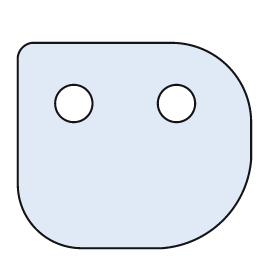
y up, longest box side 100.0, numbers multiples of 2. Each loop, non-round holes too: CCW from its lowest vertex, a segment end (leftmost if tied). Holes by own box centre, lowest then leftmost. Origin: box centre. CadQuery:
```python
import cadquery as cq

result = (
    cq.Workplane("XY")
    .moveTo(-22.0, -44.0)
    .lineTo(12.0, -44.0)
    .threePointArc((38.0, -32.0), (50.0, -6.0))
    .lineTo(50.0, 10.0)
    .threePointArc((40.0, 34.0), (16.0, 44.0))
    .lineTo(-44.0, 44.0)
    .threePointArc((-48.0, 42.0), (-50.0, 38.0))
    .lineTo(-50.0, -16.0)
    .threePointArc((-42.0, -36.0), (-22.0, -44.0))
    .close()
    .moveTo(-26.0, 18.0)
    .circle(8.0)
    .moveTo(18.0, 18.0)
    .circle(8.0)
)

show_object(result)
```